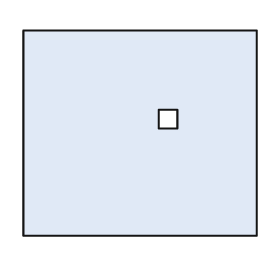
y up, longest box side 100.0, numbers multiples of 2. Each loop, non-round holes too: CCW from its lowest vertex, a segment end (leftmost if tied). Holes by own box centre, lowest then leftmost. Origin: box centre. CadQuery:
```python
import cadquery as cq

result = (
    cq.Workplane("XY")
    .moveTo(-50.0, -44.0)
    .lineTo(50.0, -44.0)
    .lineTo(50.0, 44.0)
    .lineTo(-50.0, 44.0)
    .close()
    .moveTo(8.0, 2.0)
    .lineTo(16.0, 2.0)
    .lineTo(16.0, 10.0)
    .lineTo(8.0, 10.0)
    .close()
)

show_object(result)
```